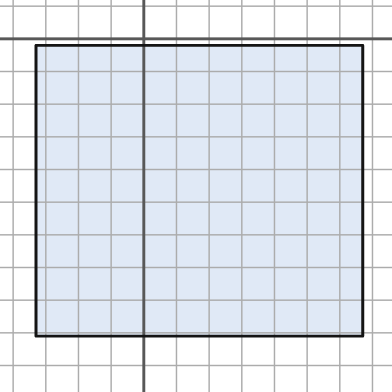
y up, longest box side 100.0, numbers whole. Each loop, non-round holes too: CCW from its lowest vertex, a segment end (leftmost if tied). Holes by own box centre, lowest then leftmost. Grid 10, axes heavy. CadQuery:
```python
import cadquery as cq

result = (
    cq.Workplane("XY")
    .moveTo(-33.0, -91.0)
    .lineTo(67.0, -91.0)
    .lineTo(67.0, -2.0)
    .lineTo(-33.0, -2.0)
    .close()
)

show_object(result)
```